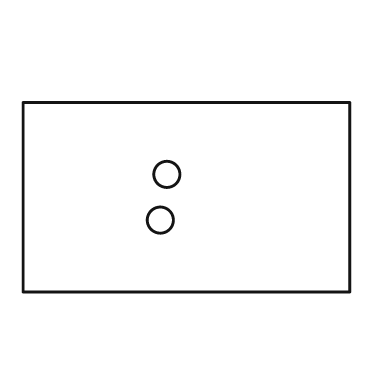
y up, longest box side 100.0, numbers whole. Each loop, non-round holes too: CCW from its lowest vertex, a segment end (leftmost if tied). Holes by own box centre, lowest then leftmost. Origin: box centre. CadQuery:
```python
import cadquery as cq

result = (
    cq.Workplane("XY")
    .moveTo(-50.0, -29.0)
    .lineTo(50.0, -29.0)
    .lineTo(50.0, 29.0)
    .lineTo(-50.0, 29.0)
    .close()
    .moveTo(-8.0, -7.0)
    .circle(4.0)
    .moveTo(-6.0, 7.0)
    .circle(4.0)
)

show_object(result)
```